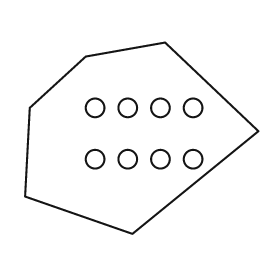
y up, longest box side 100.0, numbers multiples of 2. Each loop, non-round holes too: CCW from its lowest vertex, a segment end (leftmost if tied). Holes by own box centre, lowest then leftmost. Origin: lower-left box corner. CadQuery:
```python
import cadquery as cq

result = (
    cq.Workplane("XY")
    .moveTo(46.0, 0.0)
    .lineTo(100.0, 44.0)
    .lineTo(60.0, 82.0)
    .lineTo(26.0, 76.0)
    .lineTo(2.0, 54.0)
    .lineTo(0.0, 16.0)
    .close()
    .moveTo(30.0, 32.0)
    .circle(4.0)
    .moveTo(44.0, 32.0)
    .circle(4.0)
    .moveTo(58.0, 32.0)
    .circle(4.0)
    .moveTo(72.0, 32.0)
    .circle(4.0)
    .moveTo(30.0, 54.0)
    .circle(4.0)
    .moveTo(44.0, 54.0)
    .circle(4.0)
    .moveTo(58.0, 54.0)
    .circle(4.0)
    .moveTo(72.0, 54.0)
    .circle(4.0)
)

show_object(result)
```